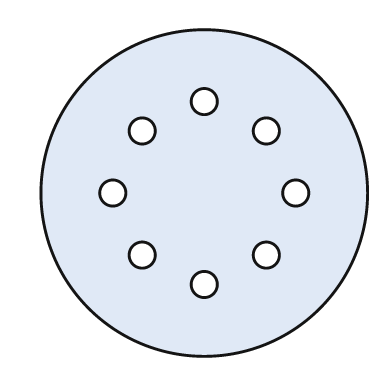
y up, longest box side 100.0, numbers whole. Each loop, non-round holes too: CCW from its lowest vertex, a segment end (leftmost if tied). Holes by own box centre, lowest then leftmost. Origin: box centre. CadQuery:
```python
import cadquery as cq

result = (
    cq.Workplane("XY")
    .moveTo(0.0, 0.0)
    .circle(50.0)
    .moveTo(0.0, -28.0)
    .circle(4.0)
    .moveTo(-19.0, -19.0)
    .circle(4.0)
    .moveTo(19.0, -19.0)
    .circle(4.0)
    .moveTo(-28.0, 0.0)
    .circle(4.0)
    .moveTo(28.0, 0.0)
    .circle(4.0)
    .moveTo(-19.0, 19.0)
    .circle(4.0)
    .moveTo(19.0, 19.0)
    .circle(4.0)
    .moveTo(0.0, 28.0)
    .circle(4.0)
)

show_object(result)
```